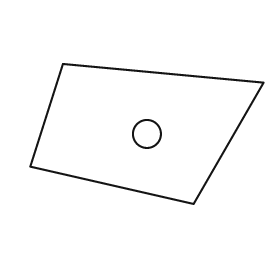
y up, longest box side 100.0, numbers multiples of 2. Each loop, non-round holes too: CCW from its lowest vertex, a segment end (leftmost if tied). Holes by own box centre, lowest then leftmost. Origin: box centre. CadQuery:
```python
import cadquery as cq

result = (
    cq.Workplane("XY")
    .moveTo(20.0, -30.0)
    .lineTo(50.0, 22.0)
    .lineTo(-36.0, 30.0)
    .lineTo(-50.0, -14.0)
    .close()
    .moveTo(0.0, 0.0)
    .circle(6.0)
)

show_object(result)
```